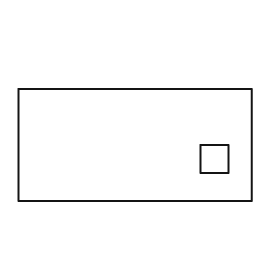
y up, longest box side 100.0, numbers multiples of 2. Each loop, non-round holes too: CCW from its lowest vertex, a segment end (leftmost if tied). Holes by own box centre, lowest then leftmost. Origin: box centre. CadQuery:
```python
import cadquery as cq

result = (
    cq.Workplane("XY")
    .moveTo(-50.0, -24.0)
    .lineTo(50.0, -24.0)
    .lineTo(50.0, 24.0)
    .lineTo(-50.0, 24.0)
    .close()
    .moveTo(28.0, -12.0)
    .lineTo(40.0, -12.0)
    .lineTo(40.0, 0.0)
    .lineTo(28.0, 0.0)
    .close()
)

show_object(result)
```